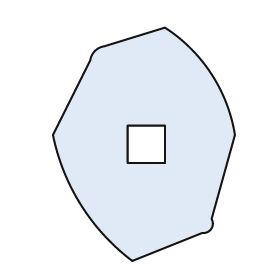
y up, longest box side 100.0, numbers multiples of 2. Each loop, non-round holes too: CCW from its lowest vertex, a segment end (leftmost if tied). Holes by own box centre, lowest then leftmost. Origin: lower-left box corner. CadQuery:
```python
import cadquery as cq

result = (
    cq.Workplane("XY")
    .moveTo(34.0, 0.0)
    .lineTo(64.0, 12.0)
    .threePointArc((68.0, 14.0), (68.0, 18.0))
    .lineTo(78.0, 54.0)
    .threePointArc((68.0, 80.0), (48.0, 100.0))
    .lineTo(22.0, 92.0)
    .threePointArc((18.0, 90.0), (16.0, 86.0))
    .lineTo(0.0, 54.0)
    .threePointArc((12.0, 24.0), (34.0, 0.0))
    .close()
    .moveTo(32.0, 42.0)
    .lineTo(48.0, 42.0)
    .lineTo(48.0, 58.0)
    .lineTo(32.0, 58.0)
    .close()
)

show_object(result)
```